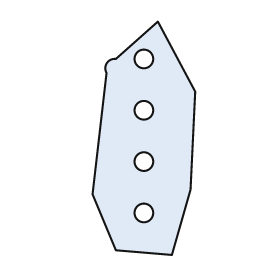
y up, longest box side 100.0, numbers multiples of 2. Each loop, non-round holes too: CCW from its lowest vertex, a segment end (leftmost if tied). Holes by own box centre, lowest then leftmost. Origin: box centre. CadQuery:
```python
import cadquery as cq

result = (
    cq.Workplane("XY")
    .moveTo(12.0, -50.0)
    .lineTo(20.0, -22.0)
    .lineTo(22.0, 20.0)
    .lineTo(6.0, 50.0)
    .lineTo(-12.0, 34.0)
    .threePointArc((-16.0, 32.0), (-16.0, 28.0))
    .lineTo(-22.0, -24.0)
    .lineTo(-12.0, -48.0)
    .close()
    .moveTo(0.0, -32.0)
    .circle(4.0)
    .moveTo(0.0, -10.0)
    .circle(4.0)
    .moveTo(0.0, 12.0)
    .circle(4.0)
    .moveTo(0.0, 34.0)
    .circle(4.0)
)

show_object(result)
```